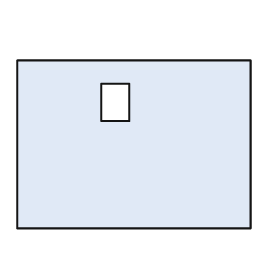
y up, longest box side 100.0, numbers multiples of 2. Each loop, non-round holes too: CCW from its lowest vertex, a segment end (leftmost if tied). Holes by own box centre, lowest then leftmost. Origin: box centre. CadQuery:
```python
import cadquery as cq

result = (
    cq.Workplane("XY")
    .moveTo(-50.0, -36.0)
    .lineTo(50.0, -36.0)
    .lineTo(50.0, 36.0)
    .lineTo(-50.0, 36.0)
    .close()
    .moveTo(-14.0, 10.0)
    .lineTo(-2.0, 10.0)
    .lineTo(-2.0, 26.0)
    .lineTo(-14.0, 26.0)
    .close()
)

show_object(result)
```